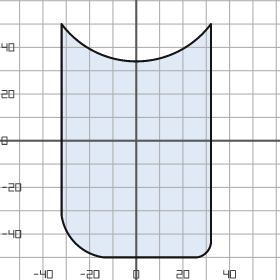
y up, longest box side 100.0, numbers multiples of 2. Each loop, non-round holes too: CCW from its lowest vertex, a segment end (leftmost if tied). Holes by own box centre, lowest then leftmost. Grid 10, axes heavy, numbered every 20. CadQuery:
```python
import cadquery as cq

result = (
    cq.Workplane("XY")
    .moveTo(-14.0, -50.0)
    .lineTo(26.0, -50.0)
    .threePointArc((30.0, -48.0), (32.0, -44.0))
    .lineTo(32.0, 50.0)
    .threePointArc((0.0, 34.0), (-32.0, 50.0))
    .lineTo(-32.0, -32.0)
    .threePointArc((-26.0, -44.0), (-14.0, -50.0))
    .close()
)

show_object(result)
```